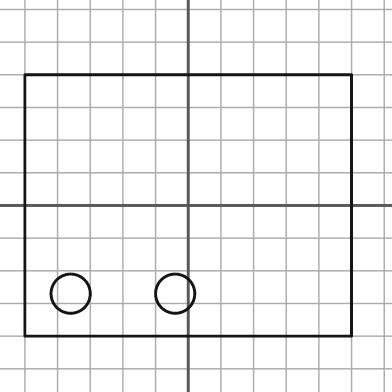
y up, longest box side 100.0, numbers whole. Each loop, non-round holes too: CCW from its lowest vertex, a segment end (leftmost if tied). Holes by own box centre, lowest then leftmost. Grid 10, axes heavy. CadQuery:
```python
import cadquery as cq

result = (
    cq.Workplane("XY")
    .moveTo(-50.0, -40.0)
    .lineTo(50.0, -40.0)
    .lineTo(50.0, 40.0)
    .lineTo(-50.0, 40.0)
    .close()
    .moveTo(-36.0, -27.0)
    .circle(6.0)
    .moveTo(-4.0, -27.0)
    .circle(6.0)
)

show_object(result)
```